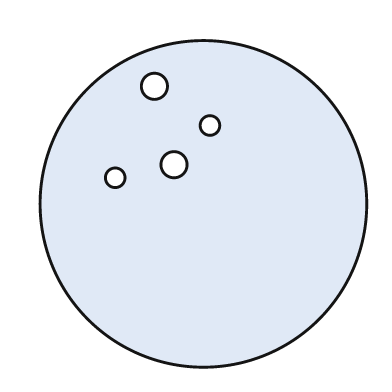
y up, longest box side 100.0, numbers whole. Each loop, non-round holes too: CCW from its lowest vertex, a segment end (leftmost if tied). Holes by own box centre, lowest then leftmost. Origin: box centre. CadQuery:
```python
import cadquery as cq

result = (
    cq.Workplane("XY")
    .moveTo(0.0, 0.0)
    .circle(50.0)
    .moveTo(-27.0, 8.0)
    .circle(3.0)
    .moveTo(-9.0, 12.0)
    .circle(4.0)
    .moveTo(2.0, 24.0)
    .circle(3.0)
    .moveTo(-15.0, 36.0)
    .circle(4.0)
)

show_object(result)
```